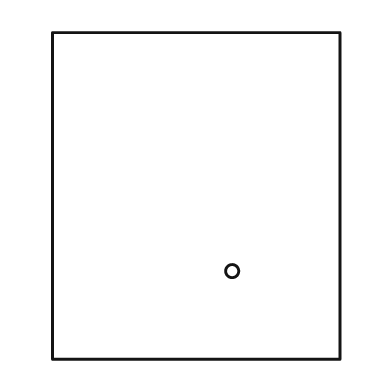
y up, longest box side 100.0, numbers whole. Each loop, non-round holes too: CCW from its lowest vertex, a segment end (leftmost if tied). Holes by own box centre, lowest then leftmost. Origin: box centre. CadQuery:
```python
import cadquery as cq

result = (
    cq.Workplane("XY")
    .moveTo(-44.0, -50.0)
    .lineTo(44.0, -50.0)
    .lineTo(44.0, 50.0)
    .lineTo(-44.0, 50.0)
    .close()
    .moveTo(11.0, -23.0)
    .circle(2.0)
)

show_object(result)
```